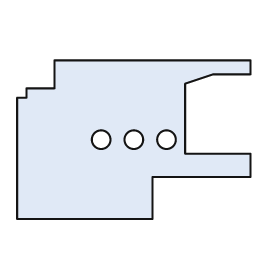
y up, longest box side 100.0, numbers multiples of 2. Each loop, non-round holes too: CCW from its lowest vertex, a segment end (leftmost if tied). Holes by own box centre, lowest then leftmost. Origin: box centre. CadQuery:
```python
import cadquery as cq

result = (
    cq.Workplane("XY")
    .moveTo(-50.0, -34.0)
    .lineTo(8.0, -34.0)
    .lineTo(8.0, -16.0)
    .lineTo(50.0, -16.0)
    .lineTo(50.0, -6.0)
    .lineTo(22.0, -6.0)
    .lineTo(22.0, 24.0)
    .lineTo(34.0, 28.0)
    .lineTo(50.0, 28.0)
    .lineTo(50.0, 34.0)
    .lineTo(-34.0, 34.0)
    .lineTo(-34.0, 22.0)
    .lineTo(-46.0, 22.0)
    .lineTo(-46.0, 18.0)
    .lineTo(-50.0, 18.0)
    .close()
    .moveTo(-14.0, 0.0)
    .circle(4.0)
    .moveTo(0.0, 0.0)
    .circle(4.0)
    .moveTo(14.0, 0.0)
    .circle(4.0)
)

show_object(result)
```